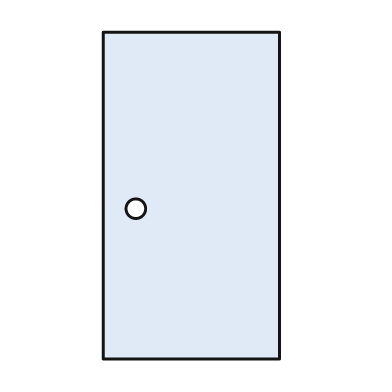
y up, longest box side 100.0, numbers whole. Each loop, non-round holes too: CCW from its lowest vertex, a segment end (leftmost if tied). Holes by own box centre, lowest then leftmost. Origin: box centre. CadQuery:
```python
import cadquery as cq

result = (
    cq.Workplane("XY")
    .moveTo(-27.0, -50.0)
    .lineTo(27.0, -50.0)
    .lineTo(27.0, 50.0)
    .lineTo(-27.0, 50.0)
    .close()
    .moveTo(-17.0, -4.0)
    .circle(3.0)
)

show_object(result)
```